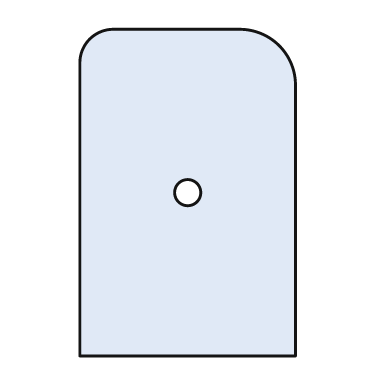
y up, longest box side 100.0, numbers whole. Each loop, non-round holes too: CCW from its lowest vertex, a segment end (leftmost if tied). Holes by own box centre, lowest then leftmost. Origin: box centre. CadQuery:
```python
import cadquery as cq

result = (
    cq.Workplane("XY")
    .moveTo(-33.0, -50.0)
    .lineTo(33.0, -50.0)
    .lineTo(33.0, 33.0)
    .threePointArc((28.0, 45.0), (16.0, 50.0))
    .lineTo(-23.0, 50.0)
    .threePointArc((-30.0, 47.0), (-33.0, 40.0))
    .close()
    .moveTo(0.0, 0.0)
    .circle(4.0)
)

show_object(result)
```